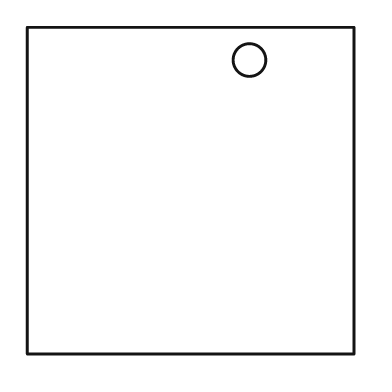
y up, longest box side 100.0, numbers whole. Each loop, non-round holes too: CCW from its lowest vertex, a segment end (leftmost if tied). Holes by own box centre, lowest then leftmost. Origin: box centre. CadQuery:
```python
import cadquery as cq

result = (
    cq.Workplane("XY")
    .moveTo(-50.0, -50.0)
    .lineTo(50.0, -50.0)
    .lineTo(50.0, 50.0)
    .lineTo(-50.0, 50.0)
    .close()
    .moveTo(18.0, 40.0)
    .circle(5.0)
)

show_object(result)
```